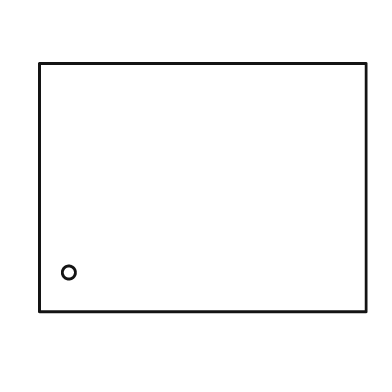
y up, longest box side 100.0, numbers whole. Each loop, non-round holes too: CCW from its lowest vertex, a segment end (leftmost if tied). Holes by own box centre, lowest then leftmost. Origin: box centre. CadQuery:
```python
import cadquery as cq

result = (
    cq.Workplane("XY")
    .moveTo(-50.0, -38.0)
    .lineTo(50.0, -38.0)
    .lineTo(50.0, 38.0)
    .lineTo(-50.0, 38.0)
    .close()
    .moveTo(-41.0, -26.0)
    .circle(2.0)
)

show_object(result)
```